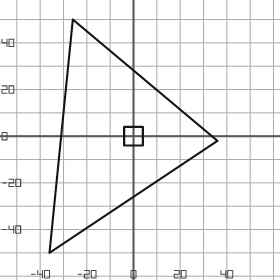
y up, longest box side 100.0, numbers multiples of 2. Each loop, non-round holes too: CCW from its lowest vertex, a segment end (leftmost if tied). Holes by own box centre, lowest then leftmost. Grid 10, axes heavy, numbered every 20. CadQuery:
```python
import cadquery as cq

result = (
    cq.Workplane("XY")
    .moveTo(-36.0, -50.0)
    .lineTo(36.0, -2.0)
    .lineTo(-26.0, 50.0)
    .close()
    .moveTo(-4.0, -4.0)
    .lineTo(4.0, -4.0)
    .lineTo(4.0, 4.0)
    .lineTo(-4.0, 4.0)
    .close()
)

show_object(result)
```